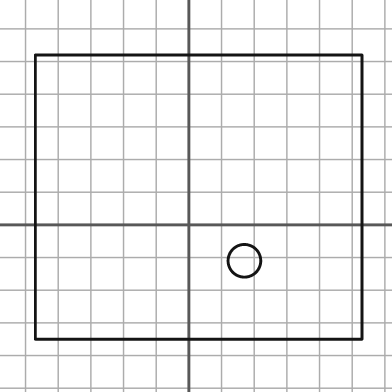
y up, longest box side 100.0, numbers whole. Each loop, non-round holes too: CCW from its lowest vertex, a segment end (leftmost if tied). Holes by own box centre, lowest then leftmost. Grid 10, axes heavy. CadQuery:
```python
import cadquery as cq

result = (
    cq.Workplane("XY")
    .moveTo(-47.0, -35.0)
    .lineTo(53.0, -35.0)
    .lineTo(53.0, 52.0)
    .lineTo(-47.0, 52.0)
    .close()
    .moveTo(17.0, -11.0)
    .circle(5.0)
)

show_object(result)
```